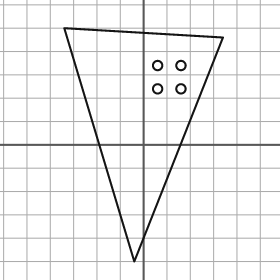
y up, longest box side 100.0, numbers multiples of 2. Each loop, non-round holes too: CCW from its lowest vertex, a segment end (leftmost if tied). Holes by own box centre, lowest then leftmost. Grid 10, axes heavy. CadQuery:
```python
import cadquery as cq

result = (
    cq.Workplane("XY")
    .moveTo(-4.0, -50.0)
    .lineTo(34.0, 46.0)
    .lineTo(-34.0, 50.0)
    .close()
    .moveTo(6.0, 24.0)
    .circle(2.0)
    .moveTo(16.0, 24.0)
    .circle(2.0)
    .moveTo(6.0, 34.0)
    .circle(2.0)
    .moveTo(16.0, 34.0)
    .circle(2.0)
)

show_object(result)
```